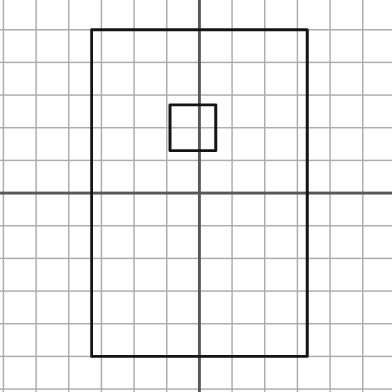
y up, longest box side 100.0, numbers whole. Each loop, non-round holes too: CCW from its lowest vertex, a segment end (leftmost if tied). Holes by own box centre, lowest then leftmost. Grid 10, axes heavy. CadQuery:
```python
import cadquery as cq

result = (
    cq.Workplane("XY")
    .moveTo(-33.0, -50.0)
    .lineTo(33.0, -50.0)
    .lineTo(33.0, 50.0)
    .lineTo(-33.0, 50.0)
    .close()
    .moveTo(-9.0, 13.0)
    .lineTo(5.0, 13.0)
    .lineTo(5.0, 27.0)
    .lineTo(-9.0, 27.0)
    .close()
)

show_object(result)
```